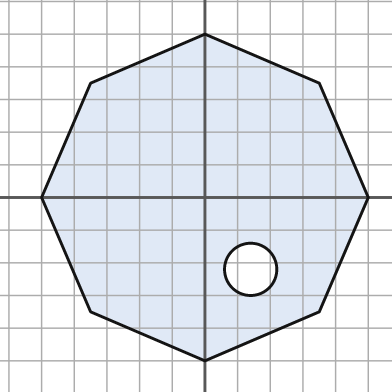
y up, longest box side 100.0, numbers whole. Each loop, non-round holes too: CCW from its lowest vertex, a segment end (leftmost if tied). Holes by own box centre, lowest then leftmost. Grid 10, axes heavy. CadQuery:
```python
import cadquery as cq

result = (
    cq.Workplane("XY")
    .moveTo(0.0, -50.0)
    .lineTo(35.0, -35.0)
    .lineTo(50.0, 0.0)
    .lineTo(35.0, 35.0)
    .lineTo(0.0, 50.0)
    .lineTo(-35.0, 35.0)
    .lineTo(-50.0, 0.0)
    .lineTo(-35.0, -35.0)
    .close()
    .moveTo(14.0, -22.0)
    .circle(8.0)
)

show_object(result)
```